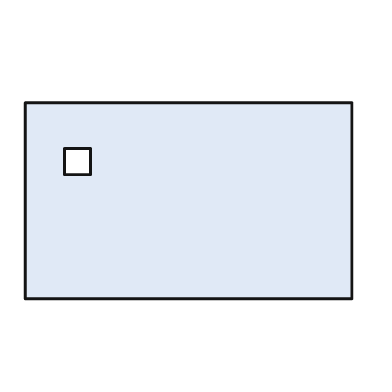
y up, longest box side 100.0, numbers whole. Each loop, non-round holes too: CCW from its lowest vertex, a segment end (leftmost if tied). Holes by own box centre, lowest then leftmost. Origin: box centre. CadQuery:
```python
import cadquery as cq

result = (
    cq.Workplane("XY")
    .moveTo(-50.0, -30.0)
    .lineTo(50.0, -30.0)
    .lineTo(50.0, 30.0)
    .lineTo(-50.0, 30.0)
    .close()
    .moveTo(-38.0, 8.0)
    .lineTo(-30.0, 8.0)
    .lineTo(-30.0, 16.0)
    .lineTo(-38.0, 16.0)
    .close()
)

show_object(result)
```